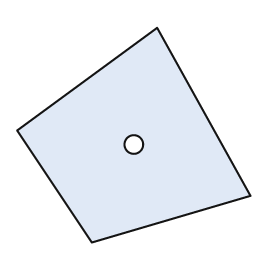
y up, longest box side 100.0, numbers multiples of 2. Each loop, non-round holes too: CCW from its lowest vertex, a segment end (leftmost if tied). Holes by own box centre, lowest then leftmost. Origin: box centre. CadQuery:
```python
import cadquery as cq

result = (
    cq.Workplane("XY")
    .moveTo(-18.0, -46.0)
    .lineTo(50.0, -26.0)
    .lineTo(10.0, 46.0)
    .lineTo(-50.0, 2.0)
    .close()
    .moveTo(0.0, -4.0)
    .circle(4.0)
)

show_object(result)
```